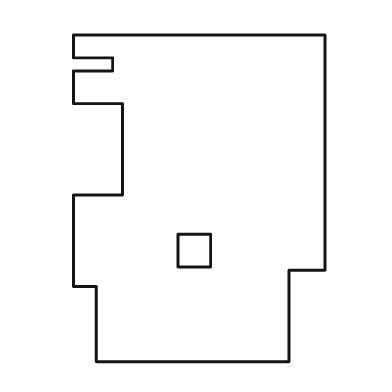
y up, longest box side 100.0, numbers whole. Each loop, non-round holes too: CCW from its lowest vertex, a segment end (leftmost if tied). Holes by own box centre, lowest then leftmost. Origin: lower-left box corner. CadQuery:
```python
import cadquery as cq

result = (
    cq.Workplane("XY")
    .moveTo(7.0, 0.0)
    .lineTo(66.0, 0.0)
    .lineTo(66.0, 28.0)
    .lineTo(77.0, 28.0)
    .lineTo(77.0, 100.0)
    .lineTo(0.0, 100.0)
    .lineTo(0.0, 93.0)
    .lineTo(12.0, 93.0)
    .lineTo(12.0, 89.0)
    .lineTo(0.0, 89.0)
    .lineTo(0.0, 79.0)
    .lineTo(15.0, 79.0)
    .lineTo(15.0, 51.0)
    .lineTo(0.0, 51.0)
    .lineTo(0.0, 23.0)
    .lineTo(7.0, 23.0)
    .close()
    .moveTo(32.0, 29.0)
    .lineTo(42.0, 29.0)
    .lineTo(42.0, 39.0)
    .lineTo(32.0, 39.0)
    .close()
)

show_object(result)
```